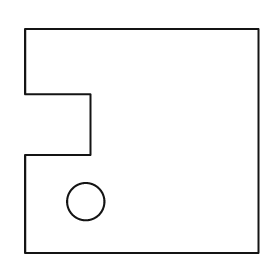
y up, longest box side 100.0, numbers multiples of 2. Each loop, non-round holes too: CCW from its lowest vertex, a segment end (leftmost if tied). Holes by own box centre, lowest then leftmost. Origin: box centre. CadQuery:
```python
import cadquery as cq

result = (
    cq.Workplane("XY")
    .moveTo(-50.0, -48.0)
    .lineTo(50.0, -48.0)
    .lineTo(50.0, 48.0)
    .lineTo(-50.0, 48.0)
    .lineTo(-50.0, 20.0)
    .lineTo(-22.0, 20.0)
    .lineTo(-22.0, -6.0)
    .lineTo(-50.0, -6.0)
    .close()
    .moveTo(-24.0, -26.0)
    .circle(8.0)
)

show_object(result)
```